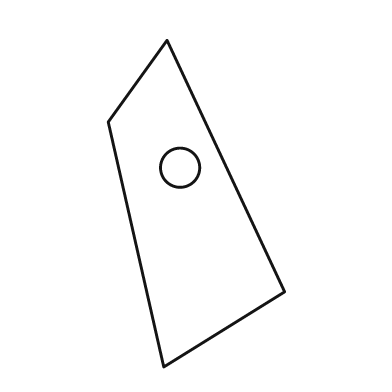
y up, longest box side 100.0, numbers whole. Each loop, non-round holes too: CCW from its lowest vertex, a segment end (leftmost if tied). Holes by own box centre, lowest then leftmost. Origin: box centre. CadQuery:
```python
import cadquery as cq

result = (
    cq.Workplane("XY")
    .moveTo(-10.0, -50.0)
    .lineTo(27.0, -27.0)
    .lineTo(-9.0, 50.0)
    .lineTo(-27.0, 25.0)
    .close()
    .moveTo(-5.0, 11.0)
    .circle(6.0)
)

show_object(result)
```